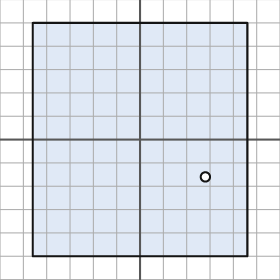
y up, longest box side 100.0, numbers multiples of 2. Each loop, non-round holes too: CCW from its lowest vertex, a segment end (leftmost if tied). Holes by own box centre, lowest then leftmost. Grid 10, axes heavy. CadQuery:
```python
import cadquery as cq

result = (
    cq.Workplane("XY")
    .moveTo(-46.0, -50.0)
    .lineTo(46.0, -50.0)
    .lineTo(46.0, 50.0)
    .lineTo(-46.0, 50.0)
    .close()
    .moveTo(28.0, -16.0)
    .circle(2.0)
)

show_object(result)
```